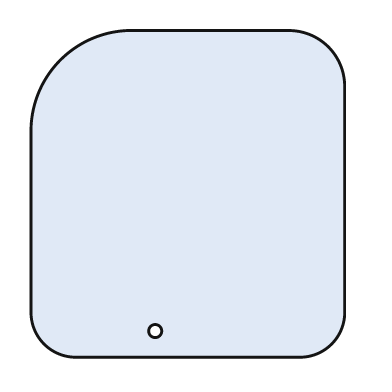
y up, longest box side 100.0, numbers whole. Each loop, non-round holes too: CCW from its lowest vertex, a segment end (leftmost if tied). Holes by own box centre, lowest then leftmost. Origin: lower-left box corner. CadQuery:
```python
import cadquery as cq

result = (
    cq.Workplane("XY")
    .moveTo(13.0, 0.0)
    .lineTo(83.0, 0.0)
    .threePointArc((92.0, 4.0), (96.0, 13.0))
    .lineTo(96.0, 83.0)
    .threePointArc((91.0, 95.0), (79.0, 100.0))
    .lineTo(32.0, 100.0)
    .threePointArc((9.0, 91.0), (0.0, 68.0))
    .lineTo(0.0, 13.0)
    .threePointArc((4.0, 4.0), (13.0, 0.0))
    .close()
    .moveTo(38.0, 8.0)
    .circle(2.0)
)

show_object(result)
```